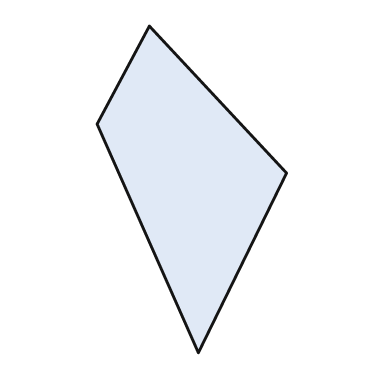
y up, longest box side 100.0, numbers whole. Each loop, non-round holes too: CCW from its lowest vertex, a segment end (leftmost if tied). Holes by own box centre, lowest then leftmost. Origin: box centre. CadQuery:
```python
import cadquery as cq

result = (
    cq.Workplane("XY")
    .moveTo(2.0, -50.0)
    .lineTo(29.0, 5.0)
    .lineTo(-13.0, 50.0)
    .lineTo(-29.0, 20.0)
    .close()
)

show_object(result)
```